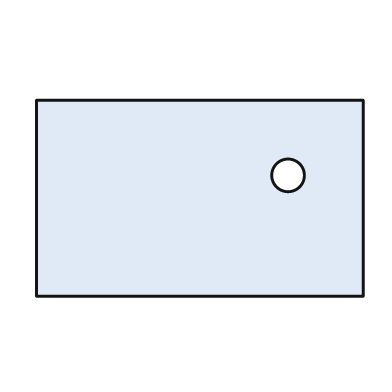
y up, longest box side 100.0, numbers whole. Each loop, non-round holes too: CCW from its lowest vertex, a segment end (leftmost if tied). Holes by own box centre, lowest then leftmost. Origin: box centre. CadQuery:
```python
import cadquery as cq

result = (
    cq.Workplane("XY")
    .moveTo(-50.0, -30.0)
    .lineTo(50.0, -30.0)
    .lineTo(50.0, 30.0)
    .lineTo(-50.0, 30.0)
    .close()
    .moveTo(27.0, 7.0)
    .circle(5.0)
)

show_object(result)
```